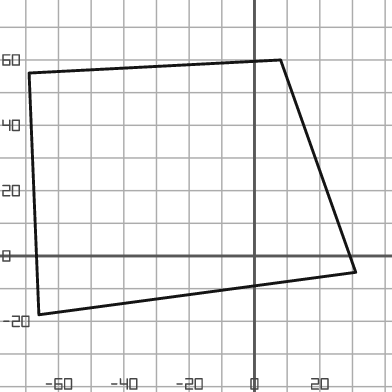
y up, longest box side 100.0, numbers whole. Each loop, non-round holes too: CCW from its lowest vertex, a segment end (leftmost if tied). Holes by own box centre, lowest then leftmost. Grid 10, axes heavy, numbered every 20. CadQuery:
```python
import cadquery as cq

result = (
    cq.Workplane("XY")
    .moveTo(-66.0, -18.0)
    .lineTo(31.0, -5.0)
    .lineTo(8.0, 60.0)
    .lineTo(-69.0, 56.0)
    .close()
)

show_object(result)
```